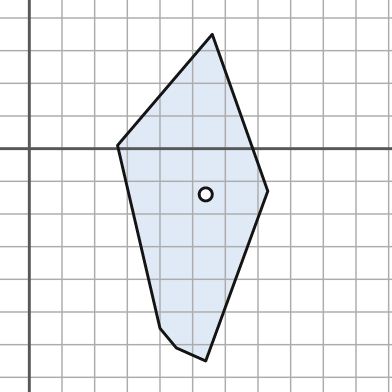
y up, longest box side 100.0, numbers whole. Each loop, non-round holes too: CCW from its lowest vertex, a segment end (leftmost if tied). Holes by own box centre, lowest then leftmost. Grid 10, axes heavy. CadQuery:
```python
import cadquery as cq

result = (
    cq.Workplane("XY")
    .moveTo(54.0, -65.0)
    .lineTo(73.0, -13.0)
    .lineTo(56.0, 35.0)
    .lineTo(27.0, 1.0)
    .lineTo(40.0, -55.0)
    .lineTo(45.0, -61.0)
    .close()
    .moveTo(54.0, -14.0)
    .circle(2.0)
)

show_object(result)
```